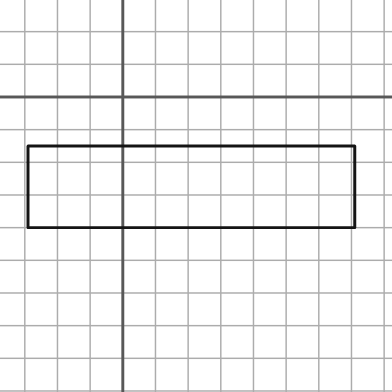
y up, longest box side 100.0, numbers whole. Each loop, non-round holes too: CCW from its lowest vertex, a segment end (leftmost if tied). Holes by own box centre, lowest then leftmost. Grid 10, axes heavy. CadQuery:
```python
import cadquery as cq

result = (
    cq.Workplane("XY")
    .moveTo(-29.0, -40.0)
    .lineTo(71.0, -40.0)
    .lineTo(71.0, -15.0)
    .lineTo(-29.0, -15.0)
    .close()
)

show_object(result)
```